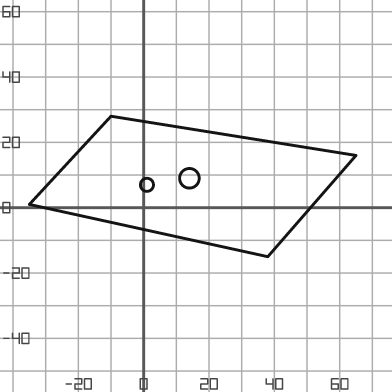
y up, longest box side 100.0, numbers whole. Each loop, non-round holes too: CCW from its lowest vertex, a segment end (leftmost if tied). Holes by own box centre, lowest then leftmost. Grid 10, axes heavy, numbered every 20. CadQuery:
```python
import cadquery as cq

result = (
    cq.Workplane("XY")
    .moveTo(38.0, -15.0)
    .lineTo(65.0, 16.0)
    .lineTo(-10.0, 28.0)
    .lineTo(-35.0, 1.0)
    .close()
    .moveTo(1.0, 7.0)
    .circle(2.0)
    .moveTo(14.0, 9.0)
    .circle(3.0)
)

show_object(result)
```